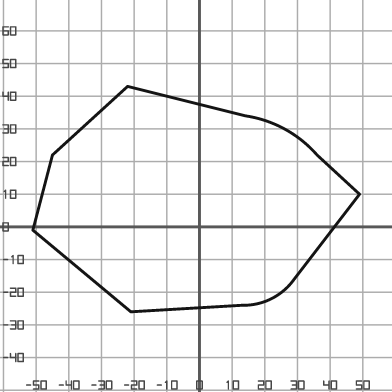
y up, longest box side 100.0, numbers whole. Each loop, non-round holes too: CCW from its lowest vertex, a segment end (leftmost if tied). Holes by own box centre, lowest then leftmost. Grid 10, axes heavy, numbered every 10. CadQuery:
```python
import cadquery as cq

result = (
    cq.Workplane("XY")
    .moveTo(-21.0, -26.0)
    .lineTo(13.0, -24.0)
    .threePointArc((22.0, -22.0), (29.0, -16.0))
    .lineTo(49.0, 10.0)
    .lineTo(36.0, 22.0)
    .threePointArc((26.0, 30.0), (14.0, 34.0))
    .lineTo(-22.0, 43.0)
    .lineTo(-45.0, 22.0)
    .lineTo(-51.0, -1.0)
    .close()
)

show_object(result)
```